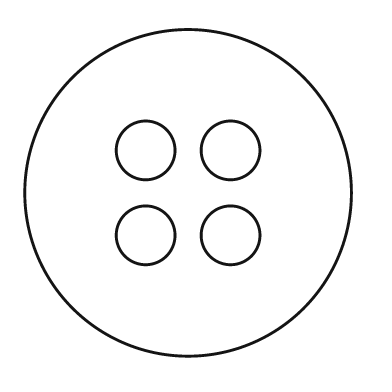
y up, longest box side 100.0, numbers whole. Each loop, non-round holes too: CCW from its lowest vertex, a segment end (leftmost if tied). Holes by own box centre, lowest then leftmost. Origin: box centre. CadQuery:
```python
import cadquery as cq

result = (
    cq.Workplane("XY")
    .moveTo(0.0, 0.0)
    .circle(50.0)
    .moveTo(-13.0, -13.0)
    .circle(9.0)
    .moveTo(13.0, -13.0)
    .circle(9.0)
    .moveTo(-13.0, 13.0)
    .circle(9.0)
    .moveTo(13.0, 13.0)
    .circle(9.0)
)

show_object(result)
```